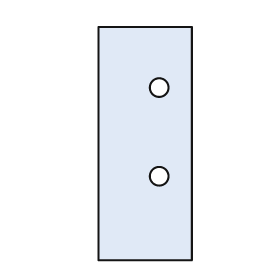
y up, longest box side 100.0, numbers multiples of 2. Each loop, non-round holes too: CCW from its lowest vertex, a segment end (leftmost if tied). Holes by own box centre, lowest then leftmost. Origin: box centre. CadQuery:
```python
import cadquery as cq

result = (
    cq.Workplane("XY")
    .moveTo(-20.0, -50.0)
    .lineTo(20.0, -50.0)
    .lineTo(20.0, 50.0)
    .lineTo(-20.0, 50.0)
    .close()
    .moveTo(6.0, -14.0)
    .circle(4.0)
    .moveTo(6.0, 24.0)
    .circle(4.0)
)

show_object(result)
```